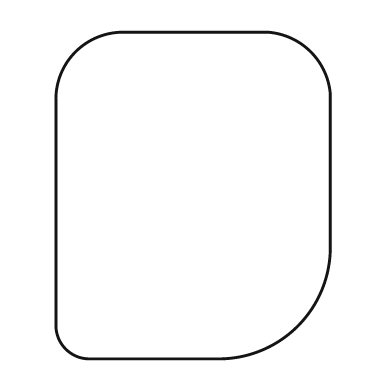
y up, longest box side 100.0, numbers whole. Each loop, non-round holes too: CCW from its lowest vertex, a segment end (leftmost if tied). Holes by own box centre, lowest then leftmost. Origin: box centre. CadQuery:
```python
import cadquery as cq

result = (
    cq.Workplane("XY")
    .moveTo(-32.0, -50.0)
    .lineTo(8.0, -50.0)
    .threePointArc((32.0, -40.0), (42.0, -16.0))
    .lineTo(42.0, 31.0)
    .threePointArc((36.0, 44.0), (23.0, 50.0))
    .lineTo(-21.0, 50.0)
    .threePointArc((-36.0, 44.0), (-42.0, 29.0))
    .lineTo(-42.0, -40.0)
    .threePointArc((-39.0, -47.0), (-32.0, -50.0))
    .close()
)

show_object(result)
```